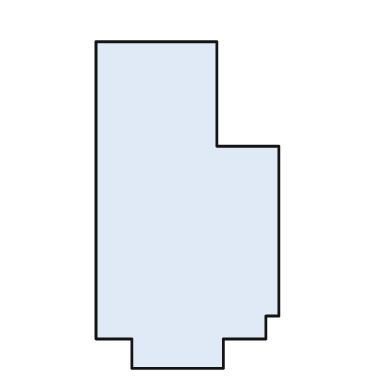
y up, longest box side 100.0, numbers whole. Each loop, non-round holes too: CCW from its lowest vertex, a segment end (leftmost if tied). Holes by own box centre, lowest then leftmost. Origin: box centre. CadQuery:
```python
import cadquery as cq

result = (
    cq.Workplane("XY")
    .moveTo(-17.0, -50.0)
    .lineTo(11.0, -50.0)
    .lineTo(11.0, -41.0)
    .lineTo(24.0, -41.0)
    .lineTo(24.0, -34.0)
    .lineTo(28.0, -34.0)
    .lineTo(28.0, 18.0)
    .lineTo(9.0, 18.0)
    .lineTo(9.0, 50.0)
    .lineTo(-28.0, 50.0)
    .lineTo(-28.0, -41.0)
    .lineTo(-17.0, -41.0)
    .close()
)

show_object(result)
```